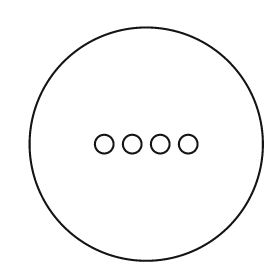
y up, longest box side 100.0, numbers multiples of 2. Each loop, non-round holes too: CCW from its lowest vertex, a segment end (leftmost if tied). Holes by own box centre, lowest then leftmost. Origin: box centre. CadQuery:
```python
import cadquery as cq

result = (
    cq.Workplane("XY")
    .moveTo(0.0, 0.0)
    .circle(50.0)
    .moveTo(-18.0, 0.0)
    .circle(4.0)
    .moveTo(-6.0, 0.0)
    .circle(4.0)
    .moveTo(6.0, 0.0)
    .circle(4.0)
    .moveTo(18.0, 0.0)
    .circle(4.0)
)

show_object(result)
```